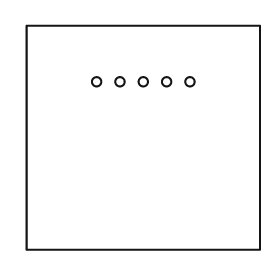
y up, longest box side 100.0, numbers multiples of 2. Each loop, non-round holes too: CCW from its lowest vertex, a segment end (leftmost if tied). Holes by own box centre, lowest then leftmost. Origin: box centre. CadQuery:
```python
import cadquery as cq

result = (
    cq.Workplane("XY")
    .moveTo(-50.0, -48.0)
    .lineTo(50.0, -48.0)
    .lineTo(50.0, 48.0)
    .lineTo(-50.0, 48.0)
    .close()
    .moveTo(-20.0, 24.0)
    .circle(2.0)
    .moveTo(-10.0, 24.0)
    .circle(2.0)
    .moveTo(0.0, 24.0)
    .circle(2.0)
    .moveTo(10.0, 24.0)
    .circle(2.0)
    .moveTo(20.0, 24.0)
    .circle(2.0)
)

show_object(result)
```